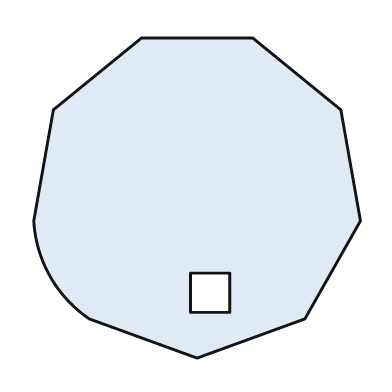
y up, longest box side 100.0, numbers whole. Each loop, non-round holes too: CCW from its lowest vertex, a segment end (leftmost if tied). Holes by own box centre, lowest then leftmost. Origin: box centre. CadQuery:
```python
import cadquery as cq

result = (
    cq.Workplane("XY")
    .moveTo(0.0, -49.0)
    .lineTo(33.0, -37.0)
    .lineTo(50.0, -7.0)
    .lineTo(44.0, 27.0)
    .lineTo(17.0, 49.0)
    .lineTo(-17.0, 49.0)
    .lineTo(-44.0, 27.0)
    .lineTo(-50.0, -7.0)
    .threePointArc((-45.0, -24.0), (-33.0, -37.0))
    .close()
    .moveTo(-2.0, -35.0)
    .lineTo(10.0, -35.0)
    .lineTo(10.0, -23.0)
    .lineTo(-2.0, -23.0)
    .close()
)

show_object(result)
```